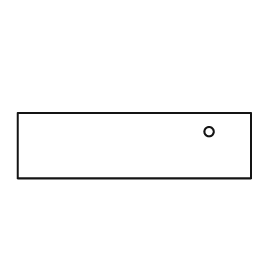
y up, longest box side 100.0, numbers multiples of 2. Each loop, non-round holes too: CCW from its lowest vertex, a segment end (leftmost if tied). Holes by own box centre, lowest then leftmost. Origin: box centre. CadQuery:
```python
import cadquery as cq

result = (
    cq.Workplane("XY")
    .moveTo(-50.0, -14.0)
    .lineTo(50.0, -14.0)
    .lineTo(50.0, 14.0)
    .lineTo(-50.0, 14.0)
    .close()
    .moveTo(32.0, 6.0)
    .circle(2.0)
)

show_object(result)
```